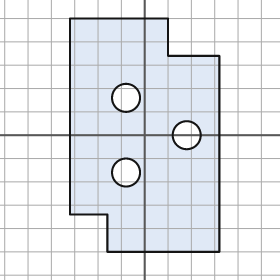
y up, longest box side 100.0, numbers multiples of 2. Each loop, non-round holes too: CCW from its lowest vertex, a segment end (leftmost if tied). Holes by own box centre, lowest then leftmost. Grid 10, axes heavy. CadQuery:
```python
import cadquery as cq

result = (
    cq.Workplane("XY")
    .moveTo(-16.0, -50.0)
    .lineTo(32.0, -50.0)
    .lineTo(32.0, 34.0)
    .lineTo(10.0, 34.0)
    .lineTo(10.0, 50.0)
    .lineTo(-32.0, 50.0)
    .lineTo(-32.0, -34.0)
    .lineTo(-16.0, -34.0)
    .close()
    .moveTo(-8.0, -16.0)
    .circle(6.0)
    .moveTo(18.0, 0.0)
    .circle(6.0)
    .moveTo(-8.0, 16.0)
    .circle(6.0)
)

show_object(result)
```